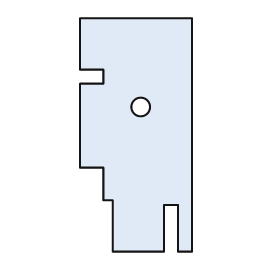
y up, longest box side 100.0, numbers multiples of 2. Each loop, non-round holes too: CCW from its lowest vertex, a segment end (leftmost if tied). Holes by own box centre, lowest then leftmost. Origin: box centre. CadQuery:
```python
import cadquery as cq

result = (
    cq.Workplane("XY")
    .moveTo(-10.0, -50.0)
    .lineTo(12.0, -50.0)
    .lineTo(12.0, -30.0)
    .lineTo(18.0, -30.0)
    .lineTo(18.0, -50.0)
    .lineTo(24.0, -50.0)
    .lineTo(24.0, 50.0)
    .lineTo(-24.0, 50.0)
    .lineTo(-24.0, 28.0)
    .lineTo(-14.0, 28.0)
    .lineTo(-14.0, 22.0)
    .lineTo(-24.0, 22.0)
    .lineTo(-24.0, -14.0)
    .lineTo(-14.0, -14.0)
    .lineTo(-14.0, -28.0)
    .lineTo(-10.0, -28.0)
    .close()
    .moveTo(2.0, 12.0)
    .circle(4.0)
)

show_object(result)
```